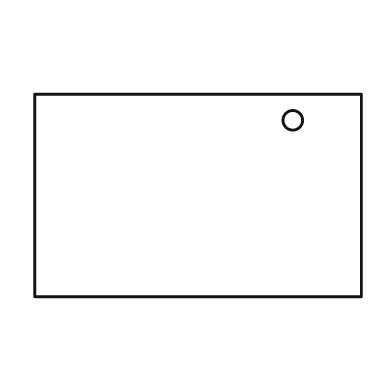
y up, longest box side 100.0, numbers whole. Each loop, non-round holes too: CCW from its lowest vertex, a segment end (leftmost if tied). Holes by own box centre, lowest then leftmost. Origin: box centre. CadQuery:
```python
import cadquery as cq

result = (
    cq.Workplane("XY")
    .moveTo(-50.0, -31.0)
    .lineTo(50.0, -31.0)
    .lineTo(50.0, 31.0)
    .lineTo(-50.0, 31.0)
    .close()
    .moveTo(29.0, 23.0)
    .circle(3.0)
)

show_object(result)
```